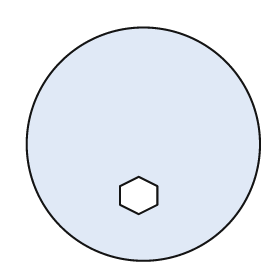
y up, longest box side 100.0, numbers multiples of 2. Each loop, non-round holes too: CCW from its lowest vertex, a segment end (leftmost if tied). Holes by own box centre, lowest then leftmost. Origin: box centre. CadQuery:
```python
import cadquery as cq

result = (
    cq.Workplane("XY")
    .moveTo(0.0, 0.0)
    .circle(50.0)
    .moveTo(-2.0, -30.0)
    .lineTo(6.0, -26.0)
    .lineTo(6.0, -18.0)
    .lineTo(-2.0, -14.0)
    .lineTo(-10.0, -18.0)
    .lineTo(-10.0, -26.0)
    .close()
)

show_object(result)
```